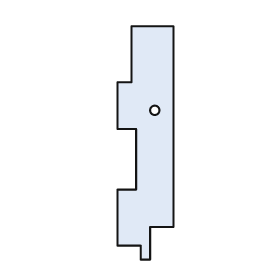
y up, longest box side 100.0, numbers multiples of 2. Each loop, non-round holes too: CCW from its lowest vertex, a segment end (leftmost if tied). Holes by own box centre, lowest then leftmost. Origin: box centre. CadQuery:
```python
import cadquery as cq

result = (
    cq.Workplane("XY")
    .moveTo(-2.0, -50.0)
    .lineTo(2.0, -50.0)
    .lineTo(2.0, -36.0)
    .lineTo(12.0, -36.0)
    .lineTo(12.0, 50.0)
    .lineTo(-6.0, 50.0)
    .lineTo(-6.0, 26.0)
    .lineTo(-12.0, 26.0)
    .lineTo(-12.0, 6.0)
    .lineTo(-4.0, 6.0)
    .lineTo(-4.0, -20.0)
    .lineTo(-12.0, -20.0)
    .lineTo(-12.0, -44.0)
    .lineTo(-2.0, -44.0)
    .close()
    .moveTo(4.0, 14.0)
    .circle(2.0)
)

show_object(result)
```